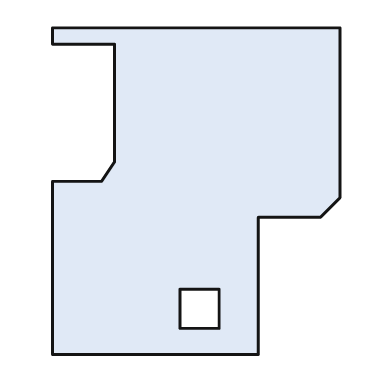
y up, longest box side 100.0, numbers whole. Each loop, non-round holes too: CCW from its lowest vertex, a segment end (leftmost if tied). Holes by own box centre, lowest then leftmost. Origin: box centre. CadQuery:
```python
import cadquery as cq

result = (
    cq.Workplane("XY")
    .moveTo(-44.0, -50.0)
    .lineTo(19.0, -50.0)
    .lineTo(19.0, -8.0)
    .lineTo(38.0, -8.0)
    .lineTo(44.0, -2.0)
    .lineTo(44.0, 50.0)
    .lineTo(-44.0, 50.0)
    .lineTo(-44.0, 45.0)
    .lineTo(-25.0, 45.0)
    .lineTo(-25.0, 9.0)
    .lineTo(-29.0, 3.0)
    .lineTo(-44.0, 3.0)
    .close()
    .moveTo(-5.0, -42.0)
    .lineTo(7.0, -42.0)
    .lineTo(7.0, -30.0)
    .lineTo(-5.0, -30.0)
    .close()
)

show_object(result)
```